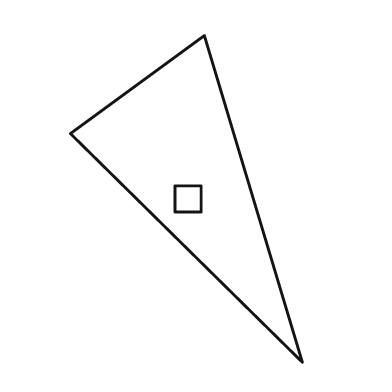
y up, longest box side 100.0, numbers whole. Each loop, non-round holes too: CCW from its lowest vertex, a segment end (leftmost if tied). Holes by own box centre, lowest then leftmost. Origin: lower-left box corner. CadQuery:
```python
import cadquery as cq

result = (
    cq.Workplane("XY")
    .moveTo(71.0, 0.0)
    .lineTo(41.0, 100.0)
    .lineTo(0.0, 70.0)
    .close()
    .moveTo(32.0, 46.0)
    .lineTo(40.0, 46.0)
    .lineTo(40.0, 54.0)
    .lineTo(32.0, 54.0)
    .close()
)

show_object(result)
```